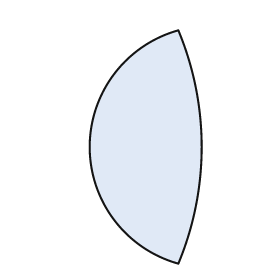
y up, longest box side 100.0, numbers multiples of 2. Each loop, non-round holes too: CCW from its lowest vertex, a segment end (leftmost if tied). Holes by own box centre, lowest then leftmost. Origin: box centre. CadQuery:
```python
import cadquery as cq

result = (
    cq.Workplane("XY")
    .moveTo(14.0, -50.0)
    .threePointArc((24.0, 0.0), (14.0, 50.0))
    .threePointArc((-24.0, 0.0), (14.0, -50.0))
    .close()
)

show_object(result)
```